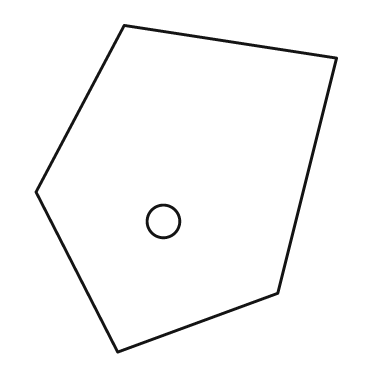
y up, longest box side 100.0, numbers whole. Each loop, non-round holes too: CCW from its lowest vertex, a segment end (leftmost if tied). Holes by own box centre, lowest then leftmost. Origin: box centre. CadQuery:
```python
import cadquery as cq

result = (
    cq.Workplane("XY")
    .moveTo(-21.0, -50.0)
    .lineTo(28.0, -32.0)
    .lineTo(46.0, 40.0)
    .lineTo(-19.0, 50.0)
    .lineTo(-46.0, -1.0)
    .close()
    .moveTo(-7.0, -10.0)
    .circle(5.0)
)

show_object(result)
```